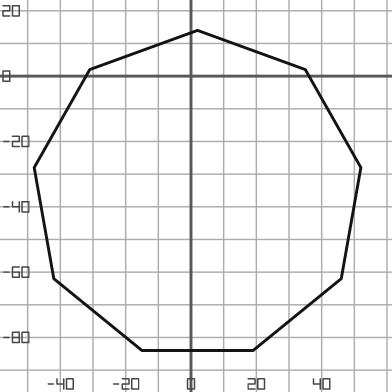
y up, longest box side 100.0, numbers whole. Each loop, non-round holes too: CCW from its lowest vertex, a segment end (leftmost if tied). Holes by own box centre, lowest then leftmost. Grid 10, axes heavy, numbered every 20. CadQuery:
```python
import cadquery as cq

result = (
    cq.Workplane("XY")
    .moveTo(-15.0, -84.0)
    .lineTo(19.0, -84.0)
    .lineTo(46.0, -62.0)
    .lineTo(52.0, -28.0)
    .lineTo(35.0, 2.0)
    .lineTo(2.0, 14.0)
    .lineTo(-31.0, 2.0)
    .lineTo(-48.0, -28.0)
    .lineTo(-42.0, -62.0)
    .close()
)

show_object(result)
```